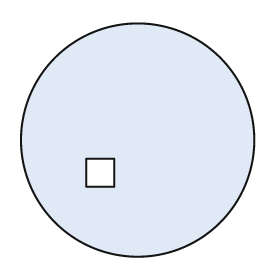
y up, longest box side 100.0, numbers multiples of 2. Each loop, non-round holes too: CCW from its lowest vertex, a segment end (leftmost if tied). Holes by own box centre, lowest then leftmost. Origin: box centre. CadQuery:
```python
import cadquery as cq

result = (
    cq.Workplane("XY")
    .moveTo(0.0, 0.0)
    .circle(50.0)
    .moveTo(-22.0, -20.0)
    .lineTo(-10.0, -20.0)
    .lineTo(-10.0, -8.0)
    .lineTo(-22.0, -8.0)
    .close()
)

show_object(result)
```